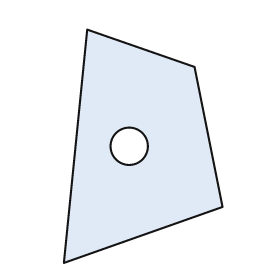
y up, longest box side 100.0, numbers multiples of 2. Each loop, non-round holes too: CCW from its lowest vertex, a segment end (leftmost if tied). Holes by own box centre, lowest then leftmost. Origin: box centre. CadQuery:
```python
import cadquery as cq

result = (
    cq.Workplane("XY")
    .moveTo(-34.0, -50.0)
    .lineTo(34.0, -26.0)
    .lineTo(22.0, 34.0)
    .lineTo(-24.0, 50.0)
    .close()
    .moveTo(-6.0, 0.0)
    .circle(8.0)
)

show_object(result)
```